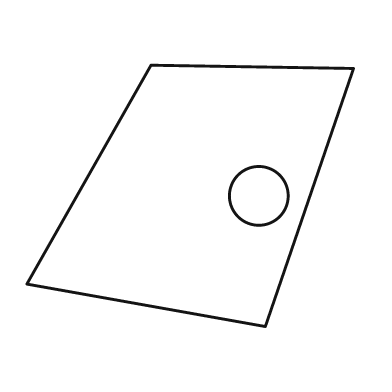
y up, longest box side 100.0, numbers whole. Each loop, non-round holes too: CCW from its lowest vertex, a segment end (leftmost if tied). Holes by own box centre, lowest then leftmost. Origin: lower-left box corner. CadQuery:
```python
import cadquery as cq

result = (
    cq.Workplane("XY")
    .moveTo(73.0, 0.0)
    .lineTo(100.0, 79.0)
    .lineTo(38.0, 80.0)
    .lineTo(0.0, 13.0)
    .close()
    .moveTo(71.0, 40.0)
    .circle(9.0)
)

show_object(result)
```